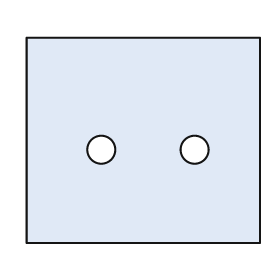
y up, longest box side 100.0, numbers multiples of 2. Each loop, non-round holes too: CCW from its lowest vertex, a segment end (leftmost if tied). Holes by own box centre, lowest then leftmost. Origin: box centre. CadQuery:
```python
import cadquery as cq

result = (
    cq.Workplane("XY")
    .moveTo(-50.0, -44.0)
    .lineTo(50.0, -44.0)
    .lineTo(50.0, 44.0)
    .lineTo(-50.0, 44.0)
    .close()
    .moveTo(-18.0, -4.0)
    .circle(6.0)
    .moveTo(22.0, -4.0)
    .circle(6.0)
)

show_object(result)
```